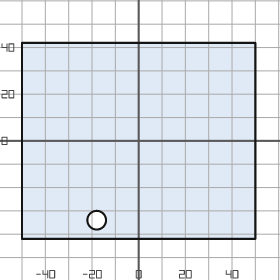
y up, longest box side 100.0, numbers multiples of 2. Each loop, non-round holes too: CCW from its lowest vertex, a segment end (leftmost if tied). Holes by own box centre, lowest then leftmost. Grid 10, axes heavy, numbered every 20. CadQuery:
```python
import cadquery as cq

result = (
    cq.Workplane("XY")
    .moveTo(-50.0, -42.0)
    .lineTo(50.0, -42.0)
    .lineTo(50.0, 42.0)
    .lineTo(-50.0, 42.0)
    .close()
    .moveTo(-18.0, -34.0)
    .circle(4.0)
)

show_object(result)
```